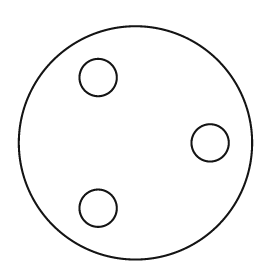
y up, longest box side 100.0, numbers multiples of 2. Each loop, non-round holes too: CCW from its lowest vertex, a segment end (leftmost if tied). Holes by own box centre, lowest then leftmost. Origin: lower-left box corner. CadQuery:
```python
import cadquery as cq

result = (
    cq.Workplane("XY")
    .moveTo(50.0, 50.0)
    .circle(50.0)
    .moveTo(34.0, 22.0)
    .circle(8.0)
    .moveTo(82.0, 50.0)
    .circle(8.0)
    .moveTo(34.0, 78.0)
    .circle(8.0)
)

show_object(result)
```